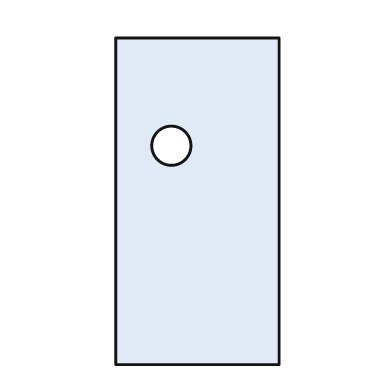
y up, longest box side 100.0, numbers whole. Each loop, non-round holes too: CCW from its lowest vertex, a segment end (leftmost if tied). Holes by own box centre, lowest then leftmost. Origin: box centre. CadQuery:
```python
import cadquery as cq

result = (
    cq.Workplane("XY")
    .moveTo(-25.0, -50.0)
    .lineTo(25.0, -50.0)
    .lineTo(25.0, 50.0)
    .lineTo(-25.0, 50.0)
    .close()
    .moveTo(-8.0, 17.0)
    .circle(6.0)
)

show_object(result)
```